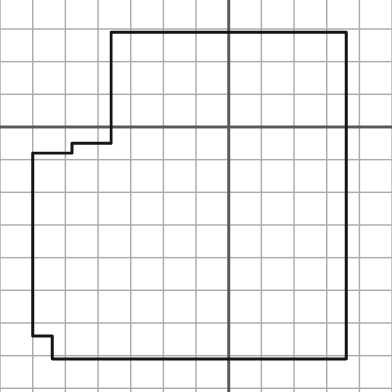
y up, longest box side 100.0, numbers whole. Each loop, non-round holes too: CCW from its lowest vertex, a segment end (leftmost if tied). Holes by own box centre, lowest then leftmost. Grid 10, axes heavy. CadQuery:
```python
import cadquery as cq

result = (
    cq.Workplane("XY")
    .moveTo(-54.0, -71.0)
    .lineTo(36.0, -71.0)
    .lineTo(36.0, 29.0)
    .lineTo(-36.0, 29.0)
    .lineTo(-36.0, -5.0)
    .lineTo(-48.0, -5.0)
    .lineTo(-48.0, -8.0)
    .lineTo(-60.0, -8.0)
    .lineTo(-60.0, -64.0)
    .lineTo(-54.0, -64.0)
    .close()
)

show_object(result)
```